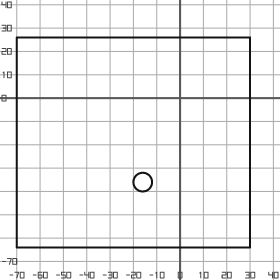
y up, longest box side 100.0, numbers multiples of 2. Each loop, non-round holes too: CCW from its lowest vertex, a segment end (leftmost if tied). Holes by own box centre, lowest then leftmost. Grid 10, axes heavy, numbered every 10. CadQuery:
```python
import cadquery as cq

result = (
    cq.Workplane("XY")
    .moveTo(-70.0, -64.0)
    .lineTo(30.0, -64.0)
    .lineTo(30.0, 26.0)
    .lineTo(-70.0, 26.0)
    .close()
    .moveTo(-16.0, -36.0)
    .circle(4.0)
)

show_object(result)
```